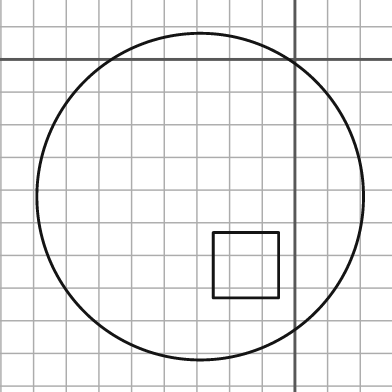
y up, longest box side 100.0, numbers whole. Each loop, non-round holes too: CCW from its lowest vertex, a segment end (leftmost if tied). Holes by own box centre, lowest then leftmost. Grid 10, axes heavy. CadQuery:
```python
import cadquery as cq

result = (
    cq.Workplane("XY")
    .moveTo(-29.0, -42.0)
    .circle(50.0)
    .moveTo(-25.0, -73.0)
    .lineTo(-5.0, -73.0)
    .lineTo(-5.0, -53.0)
    .lineTo(-25.0, -53.0)
    .close()
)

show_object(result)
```